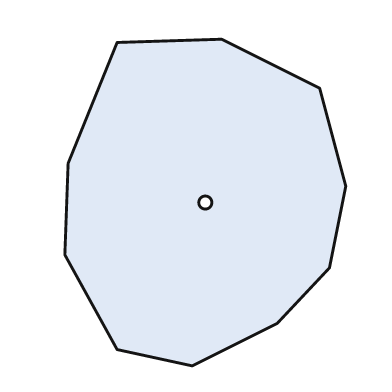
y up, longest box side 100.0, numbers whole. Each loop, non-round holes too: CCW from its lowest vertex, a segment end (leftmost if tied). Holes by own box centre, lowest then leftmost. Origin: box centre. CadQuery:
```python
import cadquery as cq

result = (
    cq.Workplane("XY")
    .moveTo(-4.0, -50.0)
    .lineTo(22.0, -37.0)
    .lineTo(38.0, -20.0)
    .lineTo(43.0, 5.0)
    .lineTo(35.0, 35.0)
    .lineTo(5.0, 50.0)
    .lineTo(-27.0, 49.0)
    .lineTo(-42.0, 12.0)
    .lineTo(-43.0, -16.0)
    .lineTo(-27.0, -45.0)
    .close()
    .moveTo(0.0, 0.0)
    .circle(2.0)
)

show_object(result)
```